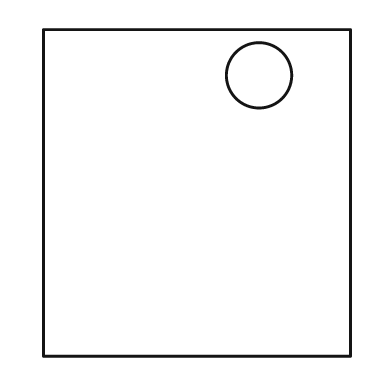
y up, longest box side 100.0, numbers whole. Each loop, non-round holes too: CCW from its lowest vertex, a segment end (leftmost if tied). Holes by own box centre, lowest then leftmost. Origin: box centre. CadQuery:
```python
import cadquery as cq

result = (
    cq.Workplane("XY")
    .moveTo(-47.0, -50.0)
    .lineTo(47.0, -50.0)
    .lineTo(47.0, 50.0)
    .lineTo(-47.0, 50.0)
    .close()
    .moveTo(19.0, 36.0)
    .circle(10.0)
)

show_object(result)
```